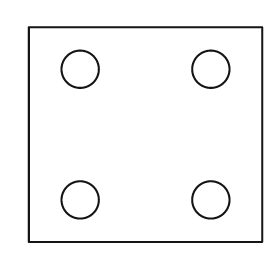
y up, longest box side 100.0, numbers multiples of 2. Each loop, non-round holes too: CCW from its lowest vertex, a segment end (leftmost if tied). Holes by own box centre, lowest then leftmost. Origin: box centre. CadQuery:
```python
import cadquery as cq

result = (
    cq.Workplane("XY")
    .moveTo(-50.0, -46.0)
    .lineTo(50.0, -46.0)
    .lineTo(50.0, 46.0)
    .lineTo(-50.0, 46.0)
    .close()
    .moveTo(-28.0, -28.0)
    .circle(8.0)
    .moveTo(28.0, -28.0)
    .circle(8.0)
    .moveTo(-28.0, 28.0)
    .circle(8.0)
    .moveTo(28.0, 28.0)
    .circle(8.0)
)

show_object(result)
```